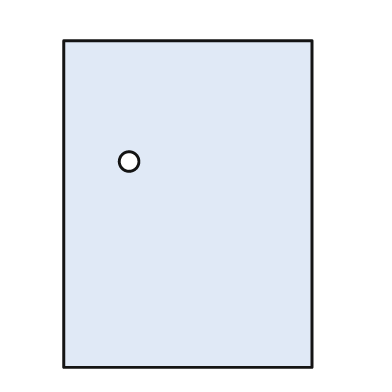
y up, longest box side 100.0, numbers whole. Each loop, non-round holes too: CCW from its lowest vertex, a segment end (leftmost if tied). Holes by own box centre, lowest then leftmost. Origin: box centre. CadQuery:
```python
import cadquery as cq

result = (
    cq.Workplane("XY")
    .moveTo(-38.0, -50.0)
    .lineTo(38.0, -50.0)
    .lineTo(38.0, 50.0)
    .lineTo(-38.0, 50.0)
    .close()
    .moveTo(-18.0, 13.0)
    .circle(3.0)
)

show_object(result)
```